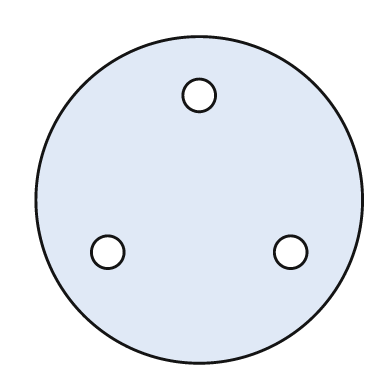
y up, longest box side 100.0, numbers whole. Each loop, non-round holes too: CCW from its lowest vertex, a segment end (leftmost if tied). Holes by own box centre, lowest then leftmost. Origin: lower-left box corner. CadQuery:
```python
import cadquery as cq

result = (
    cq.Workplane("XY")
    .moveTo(50.0, 50.0)
    .circle(50.0)
    .moveTo(22.0, 34.0)
    .circle(5.0)
    .moveTo(78.0, 34.0)
    .circle(5.0)
    .moveTo(50.0, 82.0)
    .circle(5.0)
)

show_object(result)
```